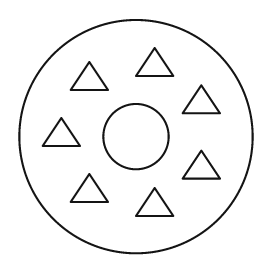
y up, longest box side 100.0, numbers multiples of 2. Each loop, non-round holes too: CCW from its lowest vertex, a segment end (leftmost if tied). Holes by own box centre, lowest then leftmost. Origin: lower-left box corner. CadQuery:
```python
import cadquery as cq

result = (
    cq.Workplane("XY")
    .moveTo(50.0, 50.0)
    .circle(50.0)
    .moveTo(50.0, 16.0)
    .lineTo(66.0, 16.0)
    .lineTo(58.0, 28.0)
    .close()
    .moveTo(22.0, 22.0)
    .lineTo(38.0, 22.0)
    .lineTo(30.0, 34.0)
    .close()
    .moveTo(70.0, 32.0)
    .lineTo(86.0, 32.0)
    .lineTo(78.0, 44.0)
    .close()
    .moveTo(50.0, 50.0)
    .circle(14.0)
    .moveTo(10.0, 46.0)
    .lineTo(26.0, 46.0)
    .lineTo(18.0, 58.0)
    .close()
    .moveTo(70.0, 60.0)
    .lineTo(86.0, 60.0)
    .lineTo(78.0, 72.0)
    .close()
    .moveTo(22.0, 70.0)
    .lineTo(38.0, 70.0)
    .lineTo(30.0, 82.0)
    .close()
    .moveTo(50.0, 76.0)
    .lineTo(66.0, 76.0)
    .lineTo(58.0, 88.0)
    .close()
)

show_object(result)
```